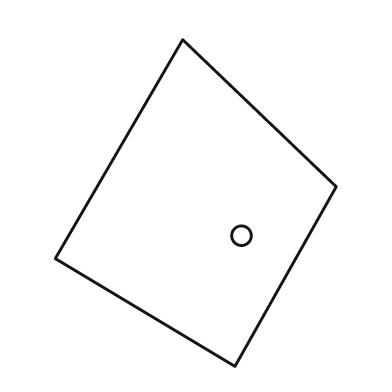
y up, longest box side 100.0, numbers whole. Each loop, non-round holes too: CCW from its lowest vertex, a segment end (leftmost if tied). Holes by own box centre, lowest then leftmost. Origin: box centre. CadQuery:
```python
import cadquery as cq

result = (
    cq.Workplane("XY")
    .moveTo(12.0, -50.0)
    .lineTo(43.0, 5.0)
    .lineTo(-4.0, 50.0)
    .lineTo(-43.0, -17.0)
    .close()
    .moveTo(14.0, -10.0)
    .circle(3.0)
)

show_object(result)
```